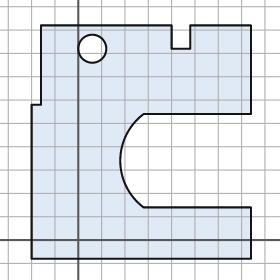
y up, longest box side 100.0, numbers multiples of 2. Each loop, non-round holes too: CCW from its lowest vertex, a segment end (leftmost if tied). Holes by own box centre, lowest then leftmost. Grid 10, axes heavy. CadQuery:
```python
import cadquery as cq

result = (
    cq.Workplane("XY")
    .moveTo(-20.0, -8.0)
    .lineTo(74.0, -8.0)
    .lineTo(74.0, 14.0)
    .lineTo(28.0, 14.0)
    .threePointArc((18.0, 34.0), (28.0, 54.0))
    .lineTo(74.0, 54.0)
    .lineTo(74.0, 92.0)
    .lineTo(48.0, 92.0)
    .lineTo(48.0, 82.0)
    .lineTo(40.0, 82.0)
    .lineTo(40.0, 92.0)
    .lineTo(-16.0, 92.0)
    .lineTo(-16.0, 58.0)
    .lineTo(-20.0, 58.0)
    .close()
    .moveTo(6.0, 82.0)
    .circle(6.0)
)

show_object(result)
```